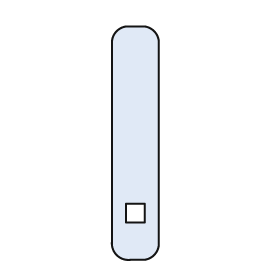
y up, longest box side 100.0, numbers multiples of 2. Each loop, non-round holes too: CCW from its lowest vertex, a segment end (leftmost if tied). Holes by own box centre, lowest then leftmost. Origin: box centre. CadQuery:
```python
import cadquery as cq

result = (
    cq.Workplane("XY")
    .moveTo(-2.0, -50.0)
    .lineTo(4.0, -50.0)
    .threePointArc((8.0, -48.0), (10.0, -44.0))
    .lineTo(10.0, 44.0)
    .threePointArc((8.0, 48.0), (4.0, 50.0))
    .lineTo(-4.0, 50.0)
    .threePointArc((-8.0, 48.0), (-10.0, 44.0))
    .lineTo(-10.0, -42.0)
    .threePointArc((-8.0, -48.0), (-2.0, -50.0))
    .close()
    .moveTo(-4.0, -34.0)
    .lineTo(4.0, -34.0)
    .lineTo(4.0, -26.0)
    .lineTo(-4.0, -26.0)
    .close()
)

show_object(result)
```